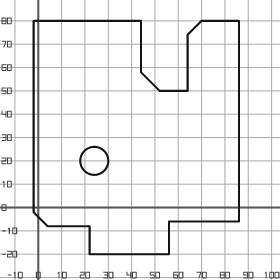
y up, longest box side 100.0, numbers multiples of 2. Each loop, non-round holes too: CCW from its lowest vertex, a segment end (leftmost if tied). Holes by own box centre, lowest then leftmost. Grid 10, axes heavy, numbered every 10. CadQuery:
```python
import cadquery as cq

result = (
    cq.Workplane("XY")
    .moveTo(22.0, -20.0)
    .lineTo(56.0, -20.0)
    .lineTo(56.0, -6.0)
    .lineTo(86.0, -6.0)
    .lineTo(86.0, 80.0)
    .lineTo(70.0, 80.0)
    .lineTo(64.0, 74.0)
    .lineTo(64.0, 50.0)
    .lineTo(52.0, 50.0)
    .lineTo(44.0, 58.0)
    .lineTo(44.0, 80.0)
    .lineTo(-2.0, 80.0)
    .lineTo(-2.0, -2.0)
    .lineTo(4.0, -8.0)
    .lineTo(22.0, -8.0)
    .close()
    .moveTo(24.0, 20.0)
    .circle(6.0)
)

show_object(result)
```